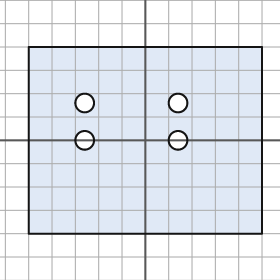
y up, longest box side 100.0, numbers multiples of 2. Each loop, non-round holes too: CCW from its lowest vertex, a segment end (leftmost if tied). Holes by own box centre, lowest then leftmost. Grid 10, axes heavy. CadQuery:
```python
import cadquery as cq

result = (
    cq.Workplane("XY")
    .moveTo(-50.0, -40.0)
    .lineTo(50.0, -40.0)
    .lineTo(50.0, 40.0)
    .lineTo(-50.0, 40.0)
    .close()
    .moveTo(-26.0, 0.0)
    .circle(4.0)
    .moveTo(14.0, 0.0)
    .circle(4.0)
    .moveTo(-26.0, 16.0)
    .circle(4.0)
    .moveTo(14.0, 16.0)
    .circle(4.0)
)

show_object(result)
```